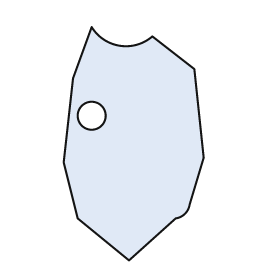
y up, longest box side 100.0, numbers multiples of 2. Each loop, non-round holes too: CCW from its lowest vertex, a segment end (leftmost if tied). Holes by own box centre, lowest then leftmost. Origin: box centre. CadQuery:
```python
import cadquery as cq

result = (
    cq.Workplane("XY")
    .moveTo(-2.0, -50.0)
    .lineTo(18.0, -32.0)
    .threePointArc((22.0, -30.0), (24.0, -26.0))
    .lineTo(30.0, -6.0)
    .lineTo(26.0, 32.0)
    .lineTo(8.0, 46.0)
    .threePointArc((-6.0, 42.0), (-18.0, 50.0))
    .lineTo(-26.0, 28.0)
    .lineTo(-30.0, -8.0)
    .lineTo(-24.0, -32.0)
    .close()
    .moveTo(-18.0, 12.0)
    .circle(6.0)
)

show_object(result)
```